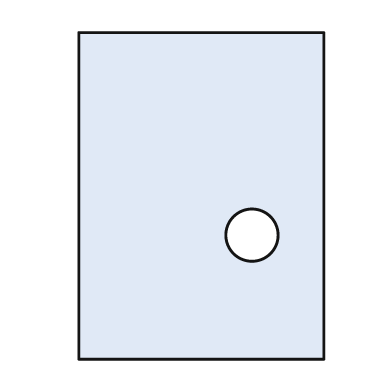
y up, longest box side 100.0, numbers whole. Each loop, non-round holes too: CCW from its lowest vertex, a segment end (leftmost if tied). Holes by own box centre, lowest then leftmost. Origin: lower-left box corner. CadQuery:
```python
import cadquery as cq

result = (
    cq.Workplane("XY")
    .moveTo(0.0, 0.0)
    .lineTo(75.0, 0.0)
    .lineTo(75.0, 100.0)
    .lineTo(0.0, 100.0)
    .close()
    .moveTo(53.0, 38.0)
    .circle(8.0)
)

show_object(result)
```